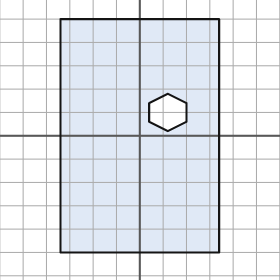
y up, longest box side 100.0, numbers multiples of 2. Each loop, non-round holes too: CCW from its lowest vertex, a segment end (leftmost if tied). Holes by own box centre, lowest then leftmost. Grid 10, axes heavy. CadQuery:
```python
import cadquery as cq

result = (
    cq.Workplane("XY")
    .moveTo(-34.0, -50.0)
    .lineTo(34.0, -50.0)
    .lineTo(34.0, 50.0)
    .lineTo(-34.0, 50.0)
    .close()
    .moveTo(12.0, 2.0)
    .lineTo(20.0, 6.0)
    .lineTo(20.0, 14.0)
    .lineTo(12.0, 18.0)
    .lineTo(4.0, 14.0)
    .lineTo(4.0, 6.0)
    .close()
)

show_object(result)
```